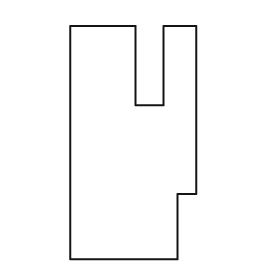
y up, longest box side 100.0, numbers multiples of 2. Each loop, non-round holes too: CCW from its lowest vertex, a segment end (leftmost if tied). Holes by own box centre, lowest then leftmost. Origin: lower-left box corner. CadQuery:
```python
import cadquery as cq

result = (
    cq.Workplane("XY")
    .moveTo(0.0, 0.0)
    .lineTo(46.0, 0.0)
    .lineTo(46.0, 28.0)
    .lineTo(54.0, 28.0)
    .lineTo(54.0, 100.0)
    .lineTo(40.0, 100.0)
    .lineTo(40.0, 66.0)
    .lineTo(28.0, 66.0)
    .lineTo(28.0, 100.0)
    .lineTo(0.0, 100.0)
    .close()
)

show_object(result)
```